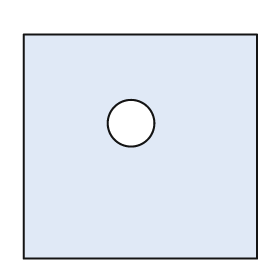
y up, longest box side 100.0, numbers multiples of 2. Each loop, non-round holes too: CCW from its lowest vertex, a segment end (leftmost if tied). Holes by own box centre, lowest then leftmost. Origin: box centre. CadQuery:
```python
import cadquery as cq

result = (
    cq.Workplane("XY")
    .moveTo(-50.0, -48.0)
    .lineTo(50.0, -48.0)
    .lineTo(50.0, 48.0)
    .lineTo(-50.0, 48.0)
    .close()
    .moveTo(-4.0, 10.0)
    .circle(10.0)
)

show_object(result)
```